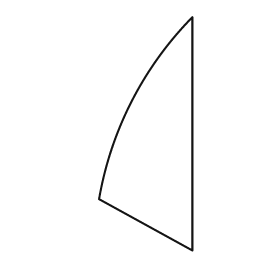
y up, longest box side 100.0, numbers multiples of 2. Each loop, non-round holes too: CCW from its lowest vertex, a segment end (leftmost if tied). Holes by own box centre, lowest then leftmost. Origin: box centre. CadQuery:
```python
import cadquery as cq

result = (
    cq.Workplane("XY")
    .moveTo(20.0, -50.0)
    .lineTo(20.0, 50.0)
    .threePointArc((-6.0, 14.0), (-20.0, -28.0))
    .close()
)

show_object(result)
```